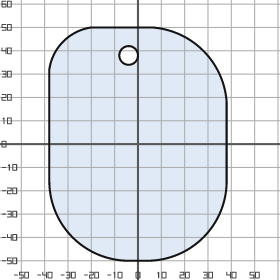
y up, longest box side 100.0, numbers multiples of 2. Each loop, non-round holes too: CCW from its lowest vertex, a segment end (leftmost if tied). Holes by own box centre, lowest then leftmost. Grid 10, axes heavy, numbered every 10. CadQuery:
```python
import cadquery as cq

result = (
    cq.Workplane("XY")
    .moveTo(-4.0, -50.0)
    .lineTo(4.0, -50.0)
    .threePointArc((28.0, -40.0), (38.0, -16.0))
    .lineTo(38.0, 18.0)
    .threePointArc((28.0, 40.0), (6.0, 50.0))
    .lineTo(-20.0, 50.0)
    .threePointArc((-32.0, 44.0), (-38.0, 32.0))
    .lineTo(-38.0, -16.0)
    .threePointArc((-28.0, -40.0), (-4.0, -50.0))
    .close()
    .moveTo(-4.0, 38.0)
    .circle(4.0)
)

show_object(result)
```